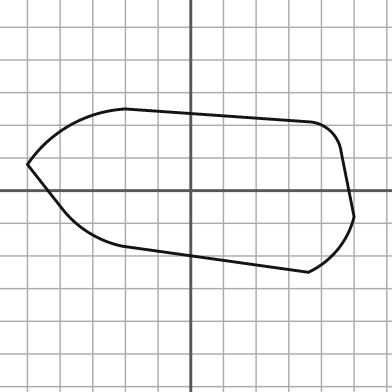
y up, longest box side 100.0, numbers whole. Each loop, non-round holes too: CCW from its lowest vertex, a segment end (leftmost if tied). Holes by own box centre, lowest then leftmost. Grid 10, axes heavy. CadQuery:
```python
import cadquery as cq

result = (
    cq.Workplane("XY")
    .moveTo(36.0, -25.0)
    .threePointArc((45.0, -18.0), (50.0, -8.0))
    .lineTo(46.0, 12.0)
    .threePointArc((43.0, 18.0), (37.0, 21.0))
    .lineTo(-20.0, 25.0)
    .threePointArc((-37.0, 20.0), (-50.0, 8.0))
    .lineTo(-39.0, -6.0)
    .threePointArc((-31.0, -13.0), (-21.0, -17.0))
    .close()
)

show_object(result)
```